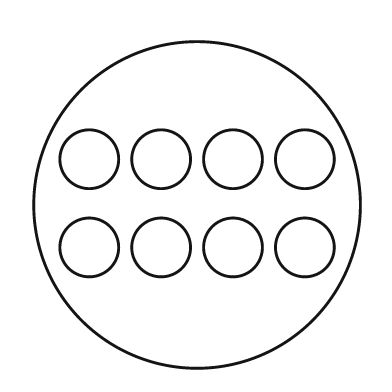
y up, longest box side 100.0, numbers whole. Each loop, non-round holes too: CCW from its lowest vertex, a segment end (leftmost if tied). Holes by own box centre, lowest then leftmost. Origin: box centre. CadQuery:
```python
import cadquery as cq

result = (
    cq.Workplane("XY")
    .moveTo(0.0, 0.0)
    .circle(50.0)
    .moveTo(-33.0, -13.0)
    .circle(9.0)
    .moveTo(-11.0, -13.0)
    .circle(9.0)
    .moveTo(11.0, -13.0)
    .circle(9.0)
    .moveTo(33.0, -13.0)
    .circle(9.0)
    .moveTo(-33.0, 14.0)
    .circle(9.0)
    .moveTo(-11.0, 14.0)
    .circle(9.0)
    .moveTo(11.0, 14.0)
    .circle(9.0)
    .moveTo(33.0, 14.0)
    .circle(9.0)
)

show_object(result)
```